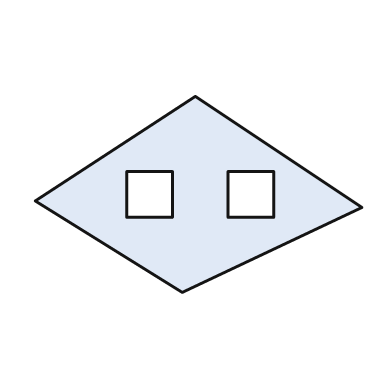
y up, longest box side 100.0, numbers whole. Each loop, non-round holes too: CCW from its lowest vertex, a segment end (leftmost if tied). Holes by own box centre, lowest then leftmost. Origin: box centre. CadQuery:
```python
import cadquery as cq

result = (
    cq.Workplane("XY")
    .moveTo(-5.0, -30.0)
    .lineTo(50.0, -4.0)
    .lineTo(-1.0, 30.0)
    .lineTo(-50.0, -2.0)
    .close()
    .moveTo(-22.0, -7.0)
    .lineTo(-8.0, -7.0)
    .lineTo(-8.0, 7.0)
    .lineTo(-22.0, 7.0)
    .close()
    .moveTo(9.0, -7.0)
    .lineTo(23.0, -7.0)
    .lineTo(23.0, 7.0)
    .lineTo(9.0, 7.0)
    .close()
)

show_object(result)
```